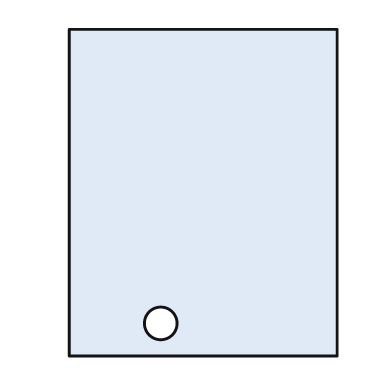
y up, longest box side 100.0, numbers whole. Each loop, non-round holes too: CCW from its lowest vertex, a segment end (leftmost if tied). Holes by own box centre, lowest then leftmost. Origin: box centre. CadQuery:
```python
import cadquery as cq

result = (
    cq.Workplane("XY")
    .moveTo(-41.0, -50.0)
    .lineTo(41.0, -50.0)
    .lineTo(41.0, 50.0)
    .lineTo(-41.0, 50.0)
    .close()
    .moveTo(-13.0, -40.0)
    .circle(5.0)
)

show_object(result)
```